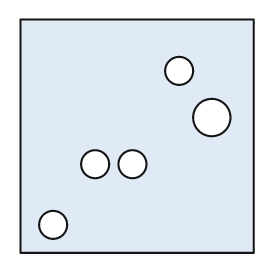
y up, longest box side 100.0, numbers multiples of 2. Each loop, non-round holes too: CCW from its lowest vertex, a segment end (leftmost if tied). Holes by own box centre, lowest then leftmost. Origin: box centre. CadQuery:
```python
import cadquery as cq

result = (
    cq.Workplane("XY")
    .moveTo(-50.0, -50.0)
    .lineTo(50.0, -50.0)
    .lineTo(50.0, 50.0)
    .lineTo(-50.0, 50.0)
    .close()
    .moveTo(-36.0, -38.0)
    .circle(6.0)
    .moveTo(-18.0, -12.0)
    .circle(6.0)
    .moveTo(-2.0, -12.0)
    .circle(6.0)
    .moveTo(32.0, 8.0)
    .circle(8.0)
    .moveTo(18.0, 28.0)
    .circle(6.0)
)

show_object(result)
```